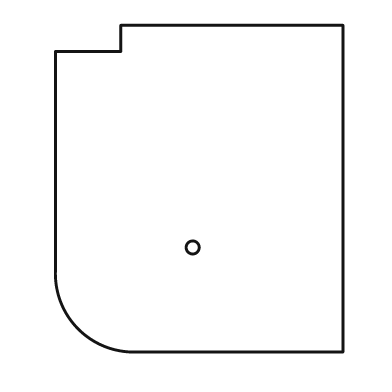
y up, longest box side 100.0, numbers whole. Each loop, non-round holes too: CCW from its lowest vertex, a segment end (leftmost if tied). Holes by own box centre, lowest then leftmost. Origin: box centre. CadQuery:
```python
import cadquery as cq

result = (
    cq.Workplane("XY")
    .moveTo(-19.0, -50.0)
    .lineTo(44.0, -50.0)
    .lineTo(44.0, 50.0)
    .lineTo(-24.0, 50.0)
    .lineTo(-24.0, 42.0)
    .lineTo(-44.0, 42.0)
    .lineTo(-44.0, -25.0)
    .threePointArc((-37.0, -43.0), (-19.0, -50.0))
    .close()
    .moveTo(-2.0, -18.0)
    .circle(2.0)
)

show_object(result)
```